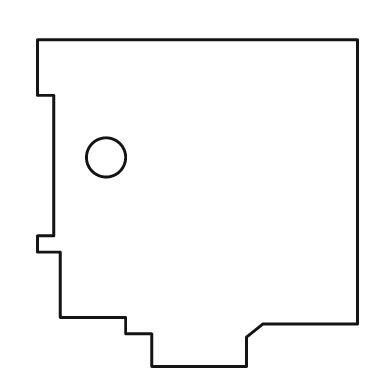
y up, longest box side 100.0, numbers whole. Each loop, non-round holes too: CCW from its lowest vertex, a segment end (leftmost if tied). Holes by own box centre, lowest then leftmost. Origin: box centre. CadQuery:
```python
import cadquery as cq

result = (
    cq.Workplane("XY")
    .moveTo(-14.0, -50.0)
    .lineTo(15.0, -50.0)
    .lineTo(15.0, -41.0)
    .lineTo(20.0, -37.0)
    .lineTo(49.0, -37.0)
    .lineTo(49.0, 50.0)
    .lineTo(-49.0, 50.0)
    .lineTo(-49.0, 33.0)
    .lineTo(-44.0, 33.0)
    .lineTo(-44.0, -10.0)
    .lineTo(-49.0, -10.0)
    .lineTo(-49.0, -15.0)
    .lineTo(-42.0, -15.0)
    .lineTo(-42.0, -35.0)
    .lineTo(-22.0, -35.0)
    .lineTo(-22.0, -40.0)
    .lineTo(-14.0, -40.0)
    .close()
    .moveTo(-28.0, 14.0)
    .circle(6.0)
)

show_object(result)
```